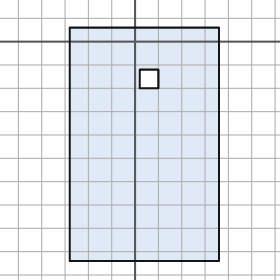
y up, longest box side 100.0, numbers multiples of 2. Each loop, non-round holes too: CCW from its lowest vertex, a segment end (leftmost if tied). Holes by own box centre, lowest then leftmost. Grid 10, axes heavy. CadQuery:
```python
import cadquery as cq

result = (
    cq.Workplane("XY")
    .moveTo(-28.0, -94.0)
    .lineTo(36.0, -94.0)
    .lineTo(36.0, 6.0)
    .lineTo(-28.0, 6.0)
    .close()
    .moveTo(2.0, -20.0)
    .lineTo(10.0, -20.0)
    .lineTo(10.0, -12.0)
    .lineTo(2.0, -12.0)
    .close()
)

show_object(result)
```